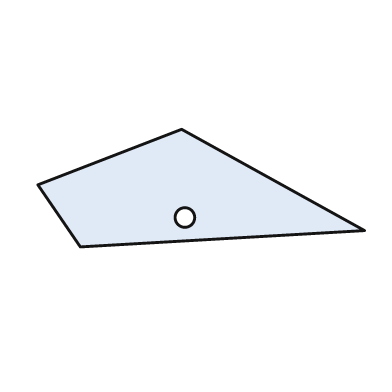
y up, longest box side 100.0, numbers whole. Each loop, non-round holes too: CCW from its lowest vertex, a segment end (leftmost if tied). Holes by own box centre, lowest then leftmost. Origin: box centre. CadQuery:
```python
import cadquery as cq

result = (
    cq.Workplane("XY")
    .moveTo(-37.0, -18.0)
    .lineTo(50.0, -13.0)
    .lineTo(-6.0, 18.0)
    .lineTo(-50.0, 1.0)
    .close()
    .moveTo(-5.0, -9.0)
    .circle(3.0)
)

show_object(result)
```